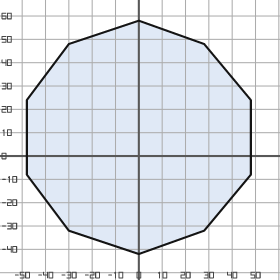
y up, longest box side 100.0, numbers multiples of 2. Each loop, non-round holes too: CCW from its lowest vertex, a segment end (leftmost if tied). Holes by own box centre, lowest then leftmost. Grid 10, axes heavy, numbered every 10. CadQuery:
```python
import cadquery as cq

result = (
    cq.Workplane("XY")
    .moveTo(0.0, -42.0)
    .lineTo(28.0, -32.0)
    .lineTo(48.0, -8.0)
    .lineTo(48.0, 24.0)
    .lineTo(28.0, 48.0)
    .lineTo(0.0, 58.0)
    .lineTo(-30.0, 48.0)
    .lineTo(-48.0, 24.0)
    .lineTo(-48.0, -8.0)
    .lineTo(-30.0, -32.0)
    .close()
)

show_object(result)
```